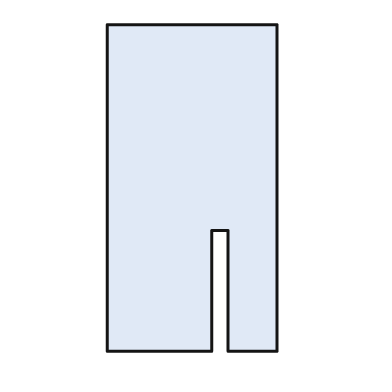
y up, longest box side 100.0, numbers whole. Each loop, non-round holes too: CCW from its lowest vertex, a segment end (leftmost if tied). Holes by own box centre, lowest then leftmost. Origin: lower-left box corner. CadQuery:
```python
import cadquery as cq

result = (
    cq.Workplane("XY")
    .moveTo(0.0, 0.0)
    .lineTo(32.0, 0.0)
    .lineTo(32.0, 37.0)
    .lineTo(37.0, 37.0)
    .lineTo(37.0, 0.0)
    .lineTo(52.0, 0.0)
    .lineTo(52.0, 100.0)
    .lineTo(0.0, 100.0)
    .close()
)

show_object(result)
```